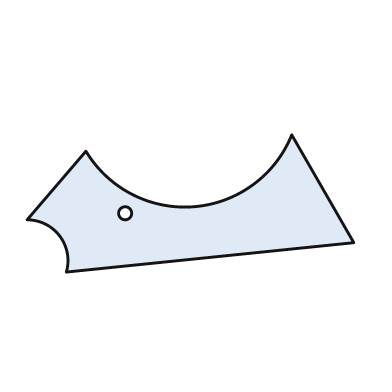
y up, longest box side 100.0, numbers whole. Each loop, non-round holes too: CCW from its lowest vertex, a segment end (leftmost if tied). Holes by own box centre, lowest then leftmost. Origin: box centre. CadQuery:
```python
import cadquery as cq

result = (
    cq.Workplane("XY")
    .moveTo(-38.0, -21.0)
    .lineTo(50.0, -12.0)
    .lineTo(31.0, 21.0)
    .threePointArc((1.0, -1.0), (-32.0, 16.0))
    .lineTo(-50.0, -5.0)
    .threePointArc((-40.0, -10.0), (-38.0, -21.0))
    .close()
    .moveTo(-20.0, -3.0)
    .circle(2.0)
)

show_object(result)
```